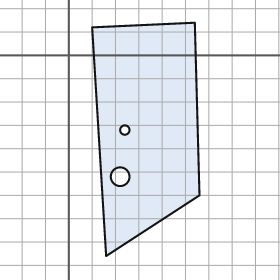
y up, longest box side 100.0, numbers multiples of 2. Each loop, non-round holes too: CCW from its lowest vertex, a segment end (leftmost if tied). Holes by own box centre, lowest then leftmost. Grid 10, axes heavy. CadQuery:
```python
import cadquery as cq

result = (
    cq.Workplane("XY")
    .moveTo(16.0, -86.0)
    .lineTo(56.0, -60.0)
    .lineTo(54.0, 14.0)
    .lineTo(10.0, 12.0)
    .close()
    .moveTo(22.0, -52.0)
    .circle(4.0)
    .moveTo(24.0, -32.0)
    .circle(2.0)
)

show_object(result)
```